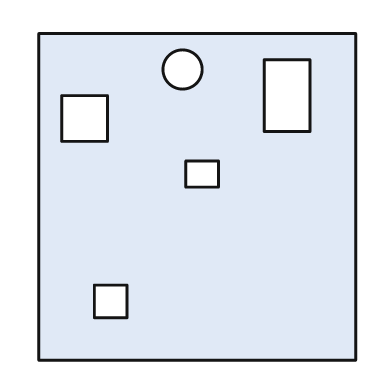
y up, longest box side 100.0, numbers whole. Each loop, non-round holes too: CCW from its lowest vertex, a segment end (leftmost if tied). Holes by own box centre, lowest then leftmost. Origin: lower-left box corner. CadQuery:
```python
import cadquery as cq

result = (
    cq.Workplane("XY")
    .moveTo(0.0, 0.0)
    .lineTo(97.0, 0.0)
    .lineTo(97.0, 100.0)
    .lineTo(0.0, 100.0)
    .close()
    .moveTo(17.0, 13.0)
    .lineTo(27.0, 13.0)
    .lineTo(27.0, 23.0)
    .lineTo(17.0, 23.0)
    .close()
    .moveTo(45.0, 53.0)
    .lineTo(55.0, 53.0)
    .lineTo(55.0, 61.0)
    .lineTo(45.0, 61.0)
    .close()
    .moveTo(7.0, 67.0)
    .lineTo(21.0, 67.0)
    .lineTo(21.0, 81.0)
    .lineTo(7.0, 81.0)
    .close()
    .moveTo(69.0, 70.0)
    .lineTo(83.0, 70.0)
    .lineTo(83.0, 92.0)
    .lineTo(69.0, 92.0)
    .close()
    .moveTo(44.0, 89.0)
    .circle(6.0)
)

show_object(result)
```